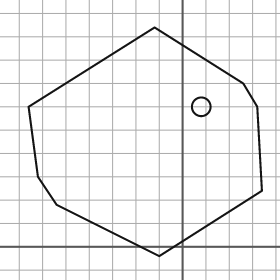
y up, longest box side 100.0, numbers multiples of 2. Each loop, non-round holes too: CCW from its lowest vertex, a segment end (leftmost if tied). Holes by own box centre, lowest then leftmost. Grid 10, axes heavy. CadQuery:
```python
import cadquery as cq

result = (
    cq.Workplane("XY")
    .moveTo(-10.0, -4.0)
    .lineTo(34.0, 24.0)
    .lineTo(32.0, 60.0)
    .lineTo(26.0, 70.0)
    .lineTo(-12.0, 94.0)
    .lineTo(-66.0, 60.0)
    .lineTo(-62.0, 30.0)
    .lineTo(-54.0, 18.0)
    .close()
    .moveTo(8.0, 60.0)
    .circle(4.0)
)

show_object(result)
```